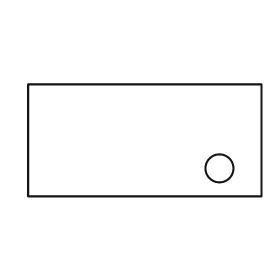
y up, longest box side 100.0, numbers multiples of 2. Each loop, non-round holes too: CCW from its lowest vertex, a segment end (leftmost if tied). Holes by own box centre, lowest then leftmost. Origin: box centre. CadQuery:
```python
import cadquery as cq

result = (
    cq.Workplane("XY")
    .moveTo(-50.0, -24.0)
    .lineTo(50.0, -24.0)
    .lineTo(50.0, 24.0)
    .lineTo(-50.0, 24.0)
    .close()
    .moveTo(32.0, -12.0)
    .circle(6.0)
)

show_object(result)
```